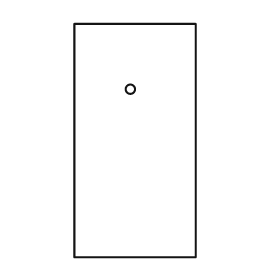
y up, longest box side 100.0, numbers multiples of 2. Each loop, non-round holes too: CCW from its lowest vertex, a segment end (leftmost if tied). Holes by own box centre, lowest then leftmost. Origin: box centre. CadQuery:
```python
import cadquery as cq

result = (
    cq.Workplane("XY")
    .moveTo(-26.0, -50.0)
    .lineTo(26.0, -50.0)
    .lineTo(26.0, 50.0)
    .lineTo(-26.0, 50.0)
    .close()
    .moveTo(-2.0, 22.0)
    .circle(2.0)
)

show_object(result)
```